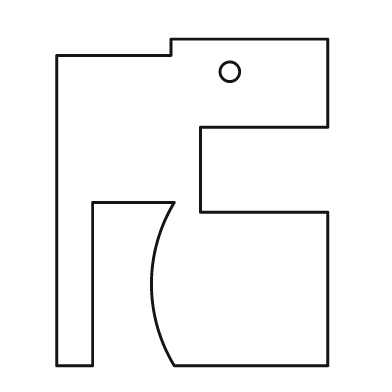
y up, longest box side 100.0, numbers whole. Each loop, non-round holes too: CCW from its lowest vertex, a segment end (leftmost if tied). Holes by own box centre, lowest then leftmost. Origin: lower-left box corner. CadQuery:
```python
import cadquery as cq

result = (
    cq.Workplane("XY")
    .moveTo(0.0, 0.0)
    .lineTo(11.0, 0.0)
    .lineTo(11.0, 50.0)
    .lineTo(36.0, 50.0)
    .threePointArc((29.0, 25.0), (36.0, 0.0))
    .lineTo(83.0, 0.0)
    .lineTo(83.0, 47.0)
    .lineTo(44.0, 47.0)
    .lineTo(44.0, 73.0)
    .lineTo(83.0, 73.0)
    .lineTo(83.0, 100.0)
    .lineTo(35.0, 100.0)
    .lineTo(35.0, 95.0)
    .lineTo(0.0, 95.0)
    .close()
    .moveTo(53.0, 90.0)
    .circle(3.0)
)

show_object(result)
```